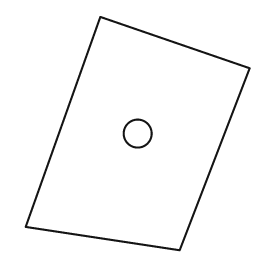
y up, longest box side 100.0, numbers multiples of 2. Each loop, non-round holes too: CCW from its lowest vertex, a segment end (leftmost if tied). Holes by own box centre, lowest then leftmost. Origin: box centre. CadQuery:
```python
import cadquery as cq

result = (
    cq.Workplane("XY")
    .moveTo(18.0, -50.0)
    .lineTo(48.0, 28.0)
    .lineTo(-16.0, 50.0)
    .lineTo(-48.0, -40.0)
    .close()
    .moveTo(0.0, 0.0)
    .circle(6.0)
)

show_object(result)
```